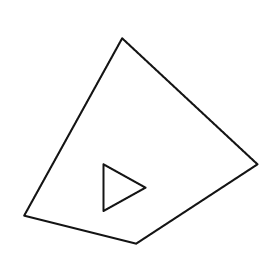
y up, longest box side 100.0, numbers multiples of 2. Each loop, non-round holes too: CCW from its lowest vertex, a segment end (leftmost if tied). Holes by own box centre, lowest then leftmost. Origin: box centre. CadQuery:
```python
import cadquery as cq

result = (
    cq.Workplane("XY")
    .moveTo(-2.0, -44.0)
    .lineTo(50.0, -10.0)
    .lineTo(-8.0, 44.0)
    .lineTo(-50.0, -32.0)
    .close()
    .moveTo(-16.0, -30.0)
    .lineTo(2.0, -20.0)
    .lineTo(-16.0, -10.0)
    .close()
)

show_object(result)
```